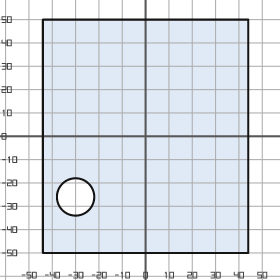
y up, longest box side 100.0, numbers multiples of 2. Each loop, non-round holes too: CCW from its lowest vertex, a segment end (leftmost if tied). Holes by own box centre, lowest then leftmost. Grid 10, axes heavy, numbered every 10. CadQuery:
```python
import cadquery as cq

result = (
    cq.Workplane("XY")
    .moveTo(-44.0, -50.0)
    .lineTo(44.0, -50.0)
    .lineTo(44.0, 50.0)
    .lineTo(-44.0, 50.0)
    .close()
    .moveTo(-30.0, -26.0)
    .circle(8.0)
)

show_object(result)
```